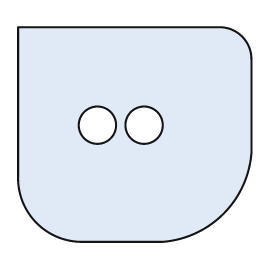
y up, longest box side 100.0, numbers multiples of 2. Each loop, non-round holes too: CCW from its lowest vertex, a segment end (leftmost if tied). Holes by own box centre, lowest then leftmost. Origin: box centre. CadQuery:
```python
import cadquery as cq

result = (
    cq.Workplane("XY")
    .moveTo(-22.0, -46.0)
    .lineTo(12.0, -46.0)
    .threePointArc((38.0, -34.0), (50.0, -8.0))
    .lineTo(50.0, 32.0)
    .threePointArc((46.0, 42.0), (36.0, 46.0))
    .lineTo(-50.0, 46.0)
    .lineTo(-50.0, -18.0)
    .threePointArc((-42.0, -38.0), (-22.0, -46.0))
    .close()
    .moveTo(-16.0, 4.0)
    .circle(8.0)
    .moveTo(4.0, 4.0)
    .circle(8.0)
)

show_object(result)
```